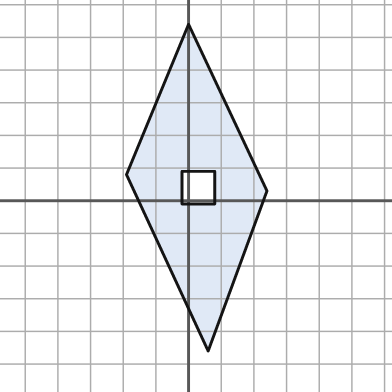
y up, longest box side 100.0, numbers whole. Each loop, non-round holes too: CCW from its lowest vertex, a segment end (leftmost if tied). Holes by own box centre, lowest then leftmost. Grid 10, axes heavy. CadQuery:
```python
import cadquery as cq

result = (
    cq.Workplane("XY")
    .moveTo(6.0, -46.0)
    .lineTo(24.0, 3.0)
    .lineTo(0.0, 54.0)
    .lineTo(-19.0, 8.0)
    .close()
    .moveTo(-2.0, -1.0)
    .lineTo(8.0, -1.0)
    .lineTo(8.0, 9.0)
    .lineTo(-2.0, 9.0)
    .close()
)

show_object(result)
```